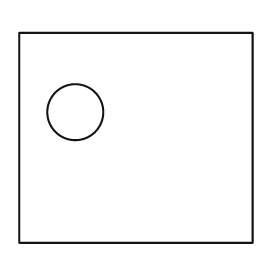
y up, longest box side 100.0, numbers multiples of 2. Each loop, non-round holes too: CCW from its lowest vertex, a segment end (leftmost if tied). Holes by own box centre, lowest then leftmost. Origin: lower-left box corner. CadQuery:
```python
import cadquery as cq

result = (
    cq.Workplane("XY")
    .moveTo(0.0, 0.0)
    .lineTo(100.0, 0.0)
    .lineTo(100.0, 90.0)
    .lineTo(0.0, 90.0)
    .close()
    .moveTo(24.0, 56.0)
    .circle(12.0)
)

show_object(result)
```